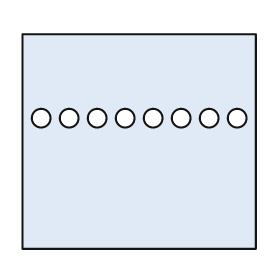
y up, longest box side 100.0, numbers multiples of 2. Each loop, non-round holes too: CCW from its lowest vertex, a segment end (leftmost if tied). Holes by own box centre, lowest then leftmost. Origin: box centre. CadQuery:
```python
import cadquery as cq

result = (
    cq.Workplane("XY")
    .moveTo(-50.0, -46.0)
    .lineTo(50.0, -46.0)
    .lineTo(50.0, 46.0)
    .lineTo(-50.0, 46.0)
    .close()
    .moveTo(-42.0, 10.0)
    .circle(4.0)
    .moveTo(-30.0, 10.0)
    .circle(4.0)
    .moveTo(-18.0, 10.0)
    .circle(4.0)
    .moveTo(-6.0, 10.0)
    .circle(4.0)
    .moveTo(6.0, 10.0)
    .circle(4.0)
    .moveTo(18.0, 10.0)
    .circle(4.0)
    .moveTo(30.0, 10.0)
    .circle(4.0)
    .moveTo(42.0, 10.0)
    .circle(4.0)
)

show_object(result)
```